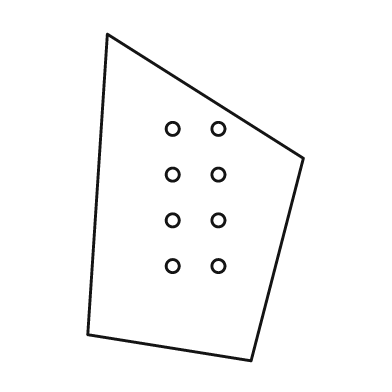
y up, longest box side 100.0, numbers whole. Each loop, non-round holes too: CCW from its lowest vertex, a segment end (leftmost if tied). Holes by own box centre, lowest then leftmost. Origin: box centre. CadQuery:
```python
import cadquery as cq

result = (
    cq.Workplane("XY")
    .moveTo(17.0, -50.0)
    .lineTo(33.0, 12.0)
    .lineTo(-27.0, 50.0)
    .lineTo(-33.0, -42.0)
    .close()
    .moveTo(-7.0, -21.0)
    .circle(2.0)
    .moveTo(7.0, -21.0)
    .circle(2.0)
    .moveTo(-7.0, -7.0)
    .circle(2.0)
    .moveTo(7.0, -7.0)
    .circle(2.0)
    .moveTo(-7.0, 7.0)
    .circle(2.0)
    .moveTo(7.0, 7.0)
    .circle(2.0)
    .moveTo(-7.0, 21.0)
    .circle(2.0)
    .moveTo(7.0, 21.0)
    .circle(2.0)
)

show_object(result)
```